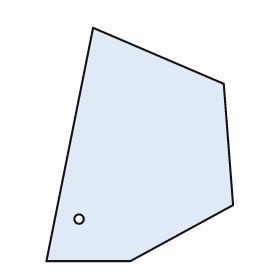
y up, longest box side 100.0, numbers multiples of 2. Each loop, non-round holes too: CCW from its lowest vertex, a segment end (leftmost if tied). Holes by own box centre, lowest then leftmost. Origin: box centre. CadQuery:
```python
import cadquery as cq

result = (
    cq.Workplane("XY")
    .moveTo(-40.0, -50.0)
    .lineTo(-4.0, -50.0)
    .lineTo(40.0, -26.0)
    .lineTo(36.0, 26.0)
    .lineTo(-20.0, 50.0)
    .close()
    .moveTo(-26.0, -32.0)
    .circle(2.0)
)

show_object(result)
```